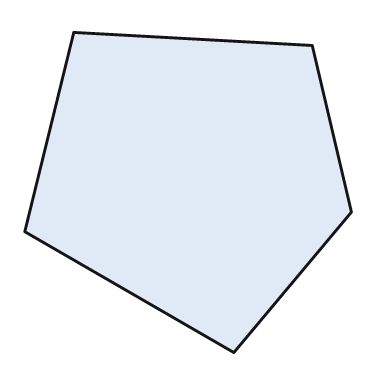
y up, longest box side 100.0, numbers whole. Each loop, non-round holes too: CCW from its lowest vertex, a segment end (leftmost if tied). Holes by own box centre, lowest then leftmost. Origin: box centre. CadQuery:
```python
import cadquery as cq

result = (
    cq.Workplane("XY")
    .moveTo(14.0, -49.0)
    .lineTo(50.0, -6.0)
    .lineTo(38.0, 45.0)
    .lineTo(-35.0, 49.0)
    .lineTo(-50.0, -12.0)
    .close()
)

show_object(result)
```